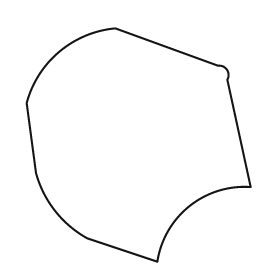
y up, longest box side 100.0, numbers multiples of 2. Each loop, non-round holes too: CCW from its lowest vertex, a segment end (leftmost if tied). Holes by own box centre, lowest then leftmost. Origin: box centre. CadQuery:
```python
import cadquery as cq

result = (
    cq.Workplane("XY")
    .moveTo(8.0, -50.0)
    .threePointArc((22.0, -26.0), (48.0, -18.0))
    .lineTo(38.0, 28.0)
    .threePointArc((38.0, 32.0), (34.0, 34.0))
    .lineTo(-10.0, 50.0)
    .threePointArc((-34.0, 40.0), (-48.0, 18.0))
    .lineTo(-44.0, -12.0)
    .threePointArc((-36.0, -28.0), (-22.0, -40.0))
    .close()
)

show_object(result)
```